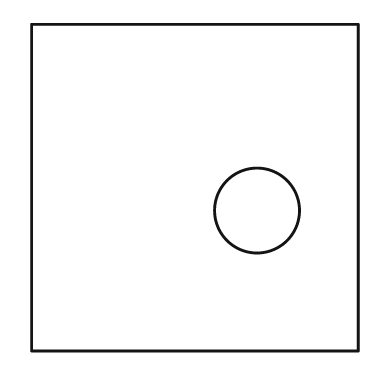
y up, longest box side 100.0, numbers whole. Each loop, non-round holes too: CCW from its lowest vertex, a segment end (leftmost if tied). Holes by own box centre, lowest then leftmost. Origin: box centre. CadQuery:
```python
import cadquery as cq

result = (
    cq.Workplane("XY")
    .moveTo(-50.0, -50.0)
    .lineTo(50.0, -50.0)
    .lineTo(50.0, 50.0)
    .lineTo(-50.0, 50.0)
    .close()
    .moveTo(19.0, -7.0)
    .circle(13.0)
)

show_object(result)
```